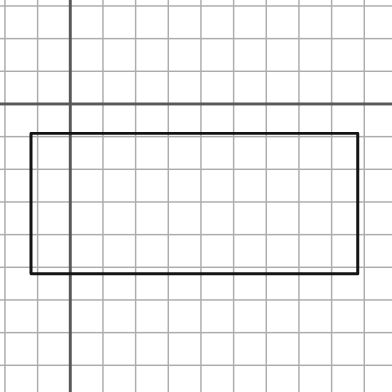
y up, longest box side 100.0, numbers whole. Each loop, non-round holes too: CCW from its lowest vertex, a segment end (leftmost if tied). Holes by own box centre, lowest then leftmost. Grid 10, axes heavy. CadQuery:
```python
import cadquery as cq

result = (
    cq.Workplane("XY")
    .moveTo(-12.0, -52.0)
    .lineTo(88.0, -52.0)
    .lineTo(88.0, -9.0)
    .lineTo(-12.0, -9.0)
    .close()
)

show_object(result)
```